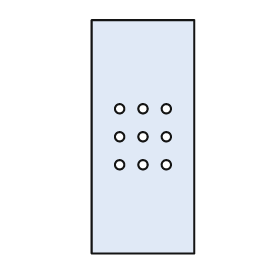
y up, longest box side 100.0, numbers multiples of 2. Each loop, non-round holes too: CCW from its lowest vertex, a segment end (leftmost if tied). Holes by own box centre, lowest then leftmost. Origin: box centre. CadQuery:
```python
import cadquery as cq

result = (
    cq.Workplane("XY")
    .moveTo(-22.0, -50.0)
    .lineTo(22.0, -50.0)
    .lineTo(22.0, 50.0)
    .lineTo(-22.0, 50.0)
    .close()
    .moveTo(-10.0, -12.0)
    .circle(2.0)
    .moveTo(0.0, -12.0)
    .circle(2.0)
    .moveTo(10.0, -12.0)
    .circle(2.0)
    .moveTo(-10.0, 0.0)
    .circle(2.0)
    .moveTo(0.0, 0.0)
    .circle(2.0)
    .moveTo(10.0, 0.0)
    .circle(2.0)
    .moveTo(-10.0, 12.0)
    .circle(2.0)
    .moveTo(0.0, 12.0)
    .circle(2.0)
    .moveTo(10.0, 12.0)
    .circle(2.0)
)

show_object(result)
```